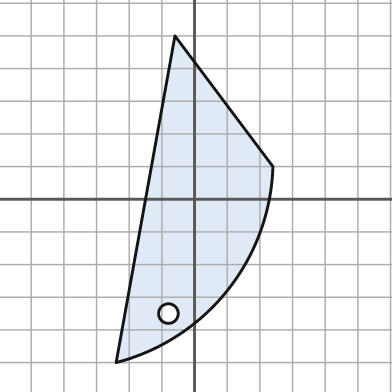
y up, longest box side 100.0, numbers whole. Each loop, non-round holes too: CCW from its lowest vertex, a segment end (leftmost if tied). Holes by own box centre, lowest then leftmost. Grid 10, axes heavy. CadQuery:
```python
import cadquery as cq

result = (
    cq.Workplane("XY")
    .moveTo(-24.0, -50.0)
    .threePointArc((10.0, -28.0), (24.0, 10.0))
    .lineTo(-6.0, 50.0)
    .close()
    .moveTo(-8.0, -35.0)
    .circle(3.0)
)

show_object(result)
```